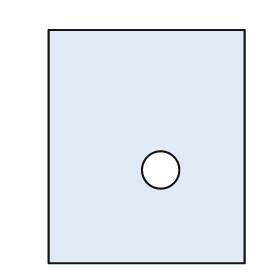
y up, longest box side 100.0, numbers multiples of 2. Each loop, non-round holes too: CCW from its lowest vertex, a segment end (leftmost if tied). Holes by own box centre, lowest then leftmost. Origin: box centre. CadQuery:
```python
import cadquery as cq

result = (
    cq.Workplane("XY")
    .moveTo(-42.0, -50.0)
    .lineTo(42.0, -50.0)
    .lineTo(42.0, 50.0)
    .lineTo(-42.0, 50.0)
    .close()
    .moveTo(6.0, -10.0)
    .circle(8.0)
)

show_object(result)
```